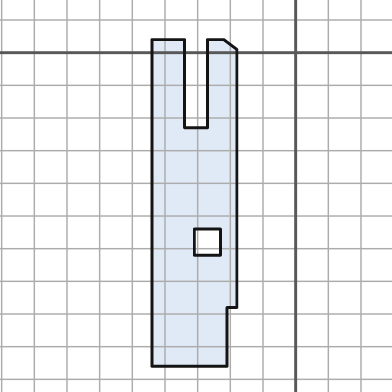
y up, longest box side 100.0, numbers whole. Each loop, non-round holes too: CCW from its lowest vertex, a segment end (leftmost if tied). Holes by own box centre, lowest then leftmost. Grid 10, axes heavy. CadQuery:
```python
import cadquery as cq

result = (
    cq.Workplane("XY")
    .moveTo(-44.0, -96.0)
    .lineTo(-21.0, -96.0)
    .lineTo(-21.0, -78.0)
    .lineTo(-18.0, -78.0)
    .lineTo(-18.0, 1.0)
    .lineTo(-22.0, 4.0)
    .lineTo(-27.0, 4.0)
    .lineTo(-27.0, -23.0)
    .lineTo(-34.0, -23.0)
    .lineTo(-34.0, 4.0)
    .lineTo(-44.0, 4.0)
    .close()
    .moveTo(-31.0, -62.0)
    .lineTo(-23.0, -62.0)
    .lineTo(-23.0, -54.0)
    .lineTo(-31.0, -54.0)
    .close()
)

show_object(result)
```